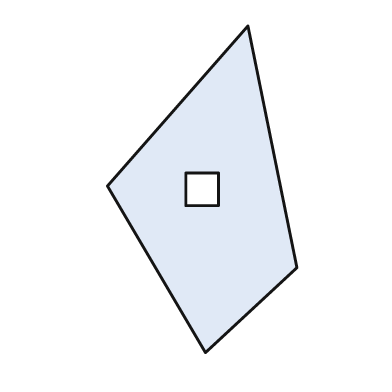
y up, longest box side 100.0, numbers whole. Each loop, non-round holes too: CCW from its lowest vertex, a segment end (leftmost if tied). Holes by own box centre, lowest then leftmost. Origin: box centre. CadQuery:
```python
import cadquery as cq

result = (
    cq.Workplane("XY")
    .moveTo(1.0, -50.0)
    .lineTo(29.0, -24.0)
    .lineTo(14.0, 50.0)
    .lineTo(-29.0, 1.0)
    .close()
    .moveTo(-5.0, -5.0)
    .lineTo(5.0, -5.0)
    .lineTo(5.0, 5.0)
    .lineTo(-5.0, 5.0)
    .close()
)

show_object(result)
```